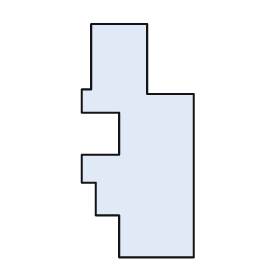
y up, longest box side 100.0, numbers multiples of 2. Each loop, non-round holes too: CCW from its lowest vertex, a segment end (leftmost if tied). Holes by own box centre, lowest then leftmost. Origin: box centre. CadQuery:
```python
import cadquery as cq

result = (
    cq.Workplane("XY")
    .moveTo(-8.0, -50.0)
    .lineTo(24.0, -50.0)
    .lineTo(24.0, 20.0)
    .lineTo(4.0, 20.0)
    .lineTo(4.0, 50.0)
    .lineTo(-20.0, 50.0)
    .lineTo(-20.0, 22.0)
    .lineTo(-24.0, 22.0)
    .lineTo(-24.0, 12.0)
    .lineTo(-8.0, 12.0)
    .lineTo(-8.0, -6.0)
    .lineTo(-24.0, -6.0)
    .lineTo(-24.0, -18.0)
    .lineTo(-18.0, -18.0)
    .lineTo(-18.0, -32.0)
    .lineTo(-8.0, -32.0)
    .close()
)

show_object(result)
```